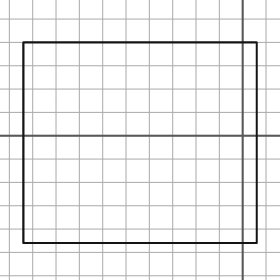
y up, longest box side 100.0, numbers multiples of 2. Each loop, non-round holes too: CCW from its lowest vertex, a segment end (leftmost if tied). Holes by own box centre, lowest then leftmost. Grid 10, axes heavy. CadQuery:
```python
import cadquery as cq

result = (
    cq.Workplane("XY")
    .moveTo(-94.0, -46.0)
    .lineTo(6.0, -46.0)
    .lineTo(6.0, 40.0)
    .lineTo(-94.0, 40.0)
    .close()
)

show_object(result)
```